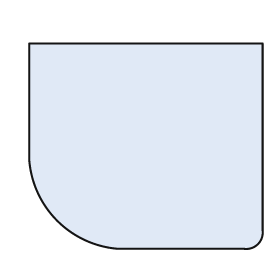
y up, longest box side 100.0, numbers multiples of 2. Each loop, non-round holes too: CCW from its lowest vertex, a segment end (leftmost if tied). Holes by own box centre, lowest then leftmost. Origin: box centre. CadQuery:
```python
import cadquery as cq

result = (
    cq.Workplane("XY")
    .moveTo(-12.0, -44.0)
    .lineTo(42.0, -44.0)
    .threePointArc((48.0, -42.0), (50.0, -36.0))
    .lineTo(50.0, 44.0)
    .lineTo(-50.0, 44.0)
    .lineTo(-50.0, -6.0)
    .threePointArc((-38.0, -32.0), (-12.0, -44.0))
    .close()
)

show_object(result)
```